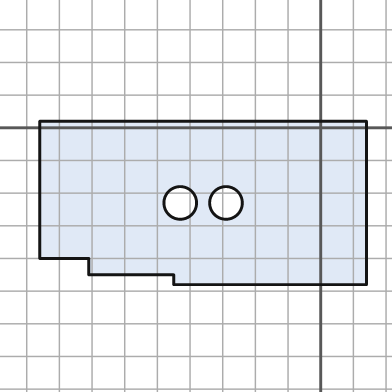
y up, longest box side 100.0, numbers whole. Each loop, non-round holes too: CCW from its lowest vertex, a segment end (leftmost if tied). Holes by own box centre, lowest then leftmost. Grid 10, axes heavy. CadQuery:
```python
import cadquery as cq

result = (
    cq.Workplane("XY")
    .moveTo(-45.0, -48.0)
    .lineTo(14.0, -48.0)
    .lineTo(14.0, 2.0)
    .lineTo(-86.0, 2.0)
    .lineTo(-86.0, -40.0)
    .lineTo(-71.0, -40.0)
    .lineTo(-71.0, -45.0)
    .lineTo(-45.0, -45.0)
    .close()
    .moveTo(-43.0, -23.0)
    .circle(5.0)
    .moveTo(-29.0, -23.0)
    .circle(5.0)
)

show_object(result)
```